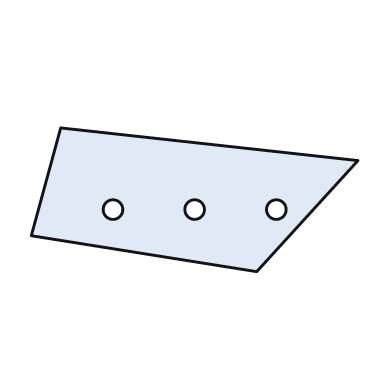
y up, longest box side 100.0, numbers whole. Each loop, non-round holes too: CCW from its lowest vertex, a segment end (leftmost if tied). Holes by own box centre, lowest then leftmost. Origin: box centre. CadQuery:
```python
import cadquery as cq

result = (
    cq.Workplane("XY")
    .moveTo(19.0, -22.0)
    .lineTo(50.0, 12.0)
    .lineTo(-41.0, 22.0)
    .lineTo(-50.0, -11.0)
    .close()
    .moveTo(-25.0, -3.0)
    .circle(3.0)
    .moveTo(0.0, -3.0)
    .circle(3.0)
    .moveTo(25.0, -3.0)
    .circle(3.0)
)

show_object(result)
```